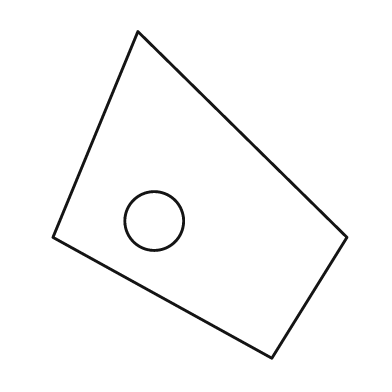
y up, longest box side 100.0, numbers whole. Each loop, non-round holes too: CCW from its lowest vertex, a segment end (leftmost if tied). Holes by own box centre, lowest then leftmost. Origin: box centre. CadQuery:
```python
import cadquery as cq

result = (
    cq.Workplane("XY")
    .moveTo(22.0, -50.0)
    .lineTo(45.0, -13.0)
    .lineTo(-19.0, 50.0)
    .lineTo(-45.0, -13.0)
    .close()
    .moveTo(-14.0, -8.0)
    .circle(9.0)
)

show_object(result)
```